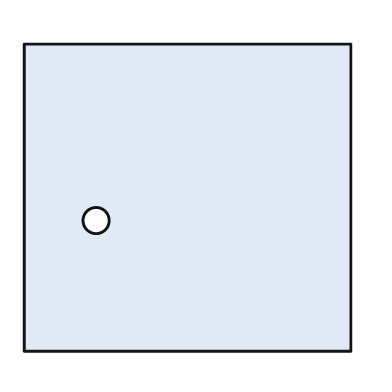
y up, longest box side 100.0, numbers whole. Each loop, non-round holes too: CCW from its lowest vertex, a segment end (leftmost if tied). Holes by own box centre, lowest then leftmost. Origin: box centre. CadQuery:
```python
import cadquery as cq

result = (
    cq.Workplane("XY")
    .moveTo(-50.0, -47.0)
    .lineTo(50.0, -47.0)
    .lineTo(50.0, 47.0)
    .lineTo(-50.0, 47.0)
    .close()
    .moveTo(-28.0, -7.0)
    .circle(4.0)
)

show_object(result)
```